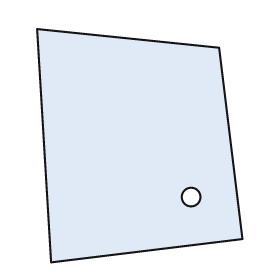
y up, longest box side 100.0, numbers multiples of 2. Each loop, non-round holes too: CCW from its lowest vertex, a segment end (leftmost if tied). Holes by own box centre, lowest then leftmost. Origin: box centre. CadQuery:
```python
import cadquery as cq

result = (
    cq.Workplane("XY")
    .moveTo(-38.0, -50.0)
    .lineTo(44.0, -40.0)
    .lineTo(34.0, 42.0)
    .lineTo(-44.0, 50.0)
    .close()
    .moveTo(22.0, -22.0)
    .circle(4.0)
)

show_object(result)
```